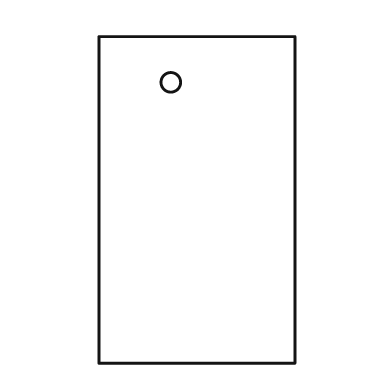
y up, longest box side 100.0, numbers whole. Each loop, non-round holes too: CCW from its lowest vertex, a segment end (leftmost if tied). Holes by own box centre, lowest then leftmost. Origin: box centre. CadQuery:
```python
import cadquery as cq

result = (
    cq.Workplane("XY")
    .moveTo(-30.0, -50.0)
    .lineTo(30.0, -50.0)
    .lineTo(30.0, 50.0)
    .lineTo(-30.0, 50.0)
    .close()
    .moveTo(-8.0, 36.0)
    .circle(3.0)
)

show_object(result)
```